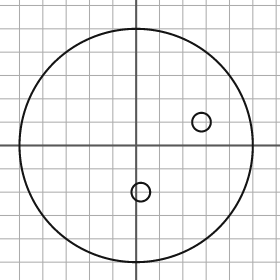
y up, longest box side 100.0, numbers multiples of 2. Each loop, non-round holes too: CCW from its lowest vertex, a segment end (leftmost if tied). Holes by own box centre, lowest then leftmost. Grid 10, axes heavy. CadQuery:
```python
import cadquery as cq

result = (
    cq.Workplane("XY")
    .moveTo(0.0, 0.0)
    .circle(50.0)
    .moveTo(2.0, -20.0)
    .circle(4.0)
    .moveTo(28.0, 10.0)
    .circle(4.0)
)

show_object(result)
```